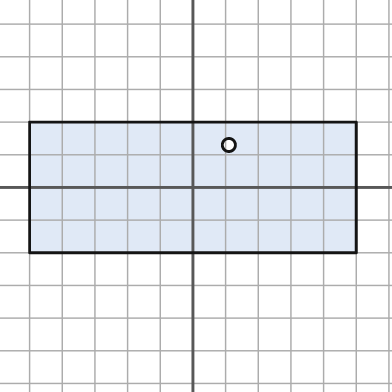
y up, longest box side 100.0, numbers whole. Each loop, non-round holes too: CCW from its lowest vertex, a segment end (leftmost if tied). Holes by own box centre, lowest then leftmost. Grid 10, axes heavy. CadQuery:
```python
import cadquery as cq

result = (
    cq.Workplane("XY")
    .moveTo(-50.0, -20.0)
    .lineTo(50.0, -20.0)
    .lineTo(50.0, 20.0)
    .lineTo(-50.0, 20.0)
    .close()
    .moveTo(11.0, 13.0)
    .circle(2.0)
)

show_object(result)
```